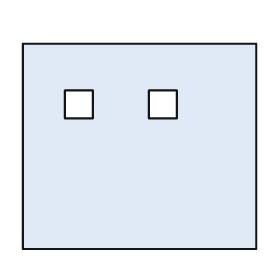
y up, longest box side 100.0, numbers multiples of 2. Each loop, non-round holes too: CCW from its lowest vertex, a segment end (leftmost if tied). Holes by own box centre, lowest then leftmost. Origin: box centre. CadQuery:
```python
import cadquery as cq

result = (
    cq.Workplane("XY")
    .moveTo(-50.0, -44.0)
    .lineTo(50.0, -44.0)
    .lineTo(50.0, 44.0)
    .lineTo(-50.0, 44.0)
    .close()
    .moveTo(-32.0, 12.0)
    .lineTo(-20.0, 12.0)
    .lineTo(-20.0, 24.0)
    .lineTo(-32.0, 24.0)
    .close()
    .moveTo(4.0, 12.0)
    .lineTo(16.0, 12.0)
    .lineTo(16.0, 24.0)
    .lineTo(4.0, 24.0)
    .close()
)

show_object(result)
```